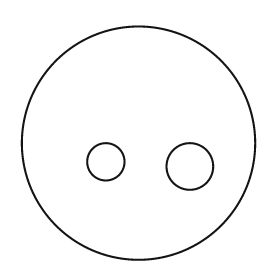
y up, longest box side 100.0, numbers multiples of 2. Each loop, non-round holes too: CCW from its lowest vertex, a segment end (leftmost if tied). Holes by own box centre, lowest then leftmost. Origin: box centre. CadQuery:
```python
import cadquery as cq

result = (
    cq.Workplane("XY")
    .moveTo(0.0, 0.0)
    .circle(50.0)
    .moveTo(22.0, -10.0)
    .circle(10.0)
    .moveTo(-14.0, -8.0)
    .circle(8.0)
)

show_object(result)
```